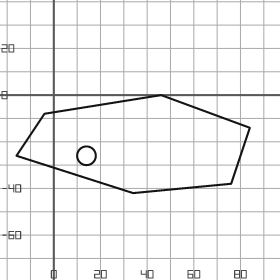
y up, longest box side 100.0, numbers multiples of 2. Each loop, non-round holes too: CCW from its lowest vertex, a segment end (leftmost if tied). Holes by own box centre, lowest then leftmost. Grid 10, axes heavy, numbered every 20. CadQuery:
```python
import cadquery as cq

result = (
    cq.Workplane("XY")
    .moveTo(34.0, -42.0)
    .lineTo(76.0, -38.0)
    .lineTo(84.0, -14.0)
    .lineTo(46.0, 0.0)
    .lineTo(-4.0, -8.0)
    .lineTo(-16.0, -26.0)
    .close()
    .moveTo(14.0, -26.0)
    .circle(4.0)
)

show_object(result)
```